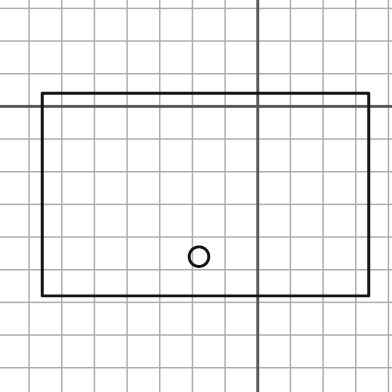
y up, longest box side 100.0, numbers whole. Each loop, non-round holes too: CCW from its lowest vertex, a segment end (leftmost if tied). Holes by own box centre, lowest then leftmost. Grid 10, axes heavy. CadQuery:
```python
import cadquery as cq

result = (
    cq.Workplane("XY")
    .moveTo(-66.0, -58.0)
    .lineTo(34.0, -58.0)
    .lineTo(34.0, 4.0)
    .lineTo(-66.0, 4.0)
    .close()
    .moveTo(-18.0, -46.0)
    .circle(3.0)
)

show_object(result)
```